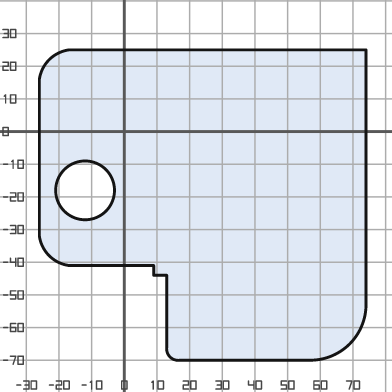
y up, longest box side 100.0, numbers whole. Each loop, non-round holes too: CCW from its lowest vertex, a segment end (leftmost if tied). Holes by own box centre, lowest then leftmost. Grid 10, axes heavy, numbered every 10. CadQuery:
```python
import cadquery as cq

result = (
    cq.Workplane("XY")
    .moveTo(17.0, -70.0)
    .lineTo(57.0, -70.0)
    .threePointArc((69.0, -65.0), (74.0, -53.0))
    .lineTo(74.0, 25.0)
    .lineTo(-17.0, 25.0)
    .threePointArc((-23.0, 22.0), (-26.0, 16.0))
    .lineTo(-26.0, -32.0)
    .threePointArc((-23.0, -38.0), (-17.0, -41.0))
    .lineTo(9.0, -41.0)
    .lineTo(9.0, -44.0)
    .lineTo(13.0, -44.0)
    .lineTo(13.0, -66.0)
    .threePointArc((14.0, -69.0), (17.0, -70.0))
    .close()
    .moveTo(-12.0, -18.0)
    .circle(9.0)
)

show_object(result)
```